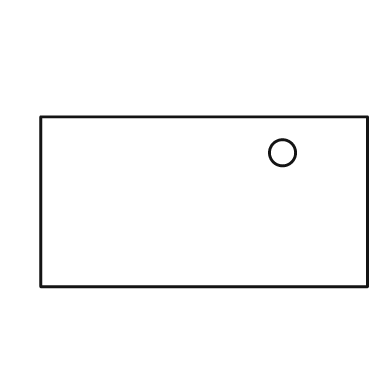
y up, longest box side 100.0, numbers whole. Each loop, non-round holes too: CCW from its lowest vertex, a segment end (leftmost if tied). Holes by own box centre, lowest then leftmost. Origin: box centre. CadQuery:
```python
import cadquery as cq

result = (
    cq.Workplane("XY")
    .moveTo(-50.0, -26.0)
    .lineTo(50.0, -26.0)
    .lineTo(50.0, 26.0)
    .lineTo(-50.0, 26.0)
    .close()
    .moveTo(24.0, 15.0)
    .circle(4.0)
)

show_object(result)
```